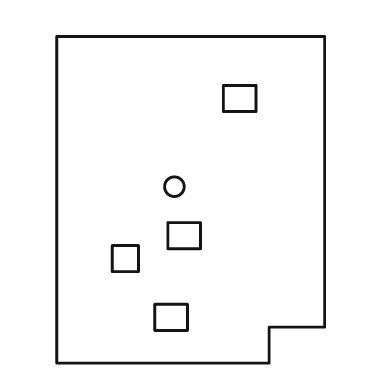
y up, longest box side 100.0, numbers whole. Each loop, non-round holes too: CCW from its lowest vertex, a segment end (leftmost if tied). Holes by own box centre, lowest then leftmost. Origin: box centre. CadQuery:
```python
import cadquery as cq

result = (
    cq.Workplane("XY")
    .moveTo(-41.0, -50.0)
    .lineTo(24.0, -50.0)
    .lineTo(24.0, -39.0)
    .lineTo(41.0, -39.0)
    .lineTo(41.0, 50.0)
    .lineTo(-41.0, 50.0)
    .close()
    .moveTo(-11.0, -40.0)
    .lineTo(-1.0, -40.0)
    .lineTo(-1.0, -32.0)
    .lineTo(-11.0, -32.0)
    .close()
    .moveTo(-24.0, -22.0)
    .lineTo(-16.0, -22.0)
    .lineTo(-16.0, -14.0)
    .lineTo(-24.0, -14.0)
    .close()
    .moveTo(-7.0, -15.0)
    .lineTo(3.0, -15.0)
    .lineTo(3.0, -7.0)
    .lineTo(-7.0, -7.0)
    .close()
    .moveTo(-5.0, 4.0)
    .circle(3.0)
    .moveTo(10.0, 27.0)
    .lineTo(20.0, 27.0)
    .lineTo(20.0, 35.0)
    .lineTo(10.0, 35.0)
    .close()
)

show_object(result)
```